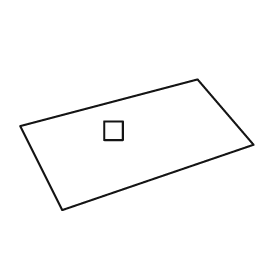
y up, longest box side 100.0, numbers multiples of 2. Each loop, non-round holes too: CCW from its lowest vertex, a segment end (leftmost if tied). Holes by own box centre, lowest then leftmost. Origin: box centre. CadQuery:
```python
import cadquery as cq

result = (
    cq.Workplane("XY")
    .moveTo(-32.0, -28.0)
    .lineTo(50.0, 0.0)
    .lineTo(26.0, 28.0)
    .lineTo(-50.0, 8.0)
    .close()
    .moveTo(-14.0, 2.0)
    .lineTo(-6.0, 2.0)
    .lineTo(-6.0, 10.0)
    .lineTo(-14.0, 10.0)
    .close()
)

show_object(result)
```